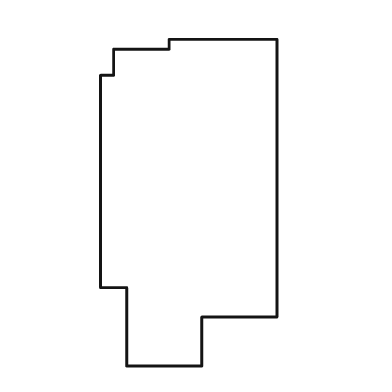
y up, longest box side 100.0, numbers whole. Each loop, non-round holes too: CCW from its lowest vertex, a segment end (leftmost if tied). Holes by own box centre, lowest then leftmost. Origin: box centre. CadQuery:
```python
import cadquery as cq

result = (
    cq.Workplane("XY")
    .moveTo(-19.0, -50.0)
    .lineTo(4.0, -50.0)
    .lineTo(4.0, -35.0)
    .lineTo(27.0, -35.0)
    .lineTo(27.0, 50.0)
    .lineTo(-6.0, 50.0)
    .lineTo(-6.0, 47.0)
    .lineTo(-23.0, 47.0)
    .lineTo(-23.0, 39.0)
    .lineTo(-27.0, 39.0)
    .lineTo(-27.0, -26.0)
    .lineTo(-19.0, -26.0)
    .close()
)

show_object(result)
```